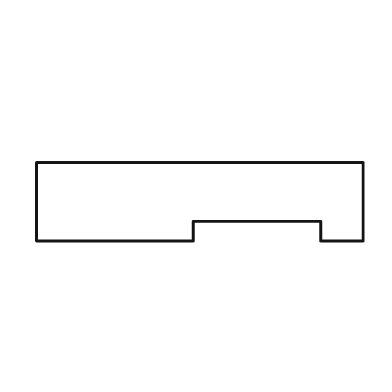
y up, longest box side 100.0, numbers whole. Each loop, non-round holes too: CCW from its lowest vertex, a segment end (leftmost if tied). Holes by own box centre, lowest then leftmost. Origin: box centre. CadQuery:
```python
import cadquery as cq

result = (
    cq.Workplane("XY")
    .moveTo(-50.0, -12.0)
    .lineTo(-2.0, -12.0)
    .lineTo(-2.0, -6.0)
    .lineTo(37.0, -6.0)
    .lineTo(37.0, -12.0)
    .lineTo(50.0, -12.0)
    .lineTo(50.0, 12.0)
    .lineTo(-50.0, 12.0)
    .close()
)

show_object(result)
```